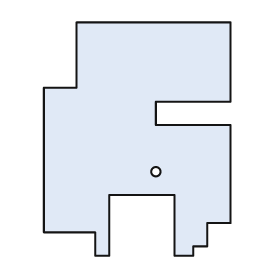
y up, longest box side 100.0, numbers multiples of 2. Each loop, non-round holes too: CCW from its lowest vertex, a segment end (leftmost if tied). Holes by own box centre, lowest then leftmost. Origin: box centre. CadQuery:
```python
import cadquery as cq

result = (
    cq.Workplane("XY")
    .moveTo(-18.0, -50.0)
    .lineTo(-12.0, -50.0)
    .lineTo(-12.0, -24.0)
    .lineTo(16.0, -24.0)
    .lineTo(16.0, -50.0)
    .lineTo(24.0, -50.0)
    .lineTo(24.0, -46.0)
    .lineTo(30.0, -46.0)
    .lineTo(30.0, -36.0)
    .lineTo(40.0, -36.0)
    .lineTo(40.0, 6.0)
    .lineTo(8.0, 6.0)
    .lineTo(8.0, 16.0)
    .lineTo(40.0, 16.0)
    .lineTo(40.0, 50.0)
    .lineTo(-26.0, 50.0)
    .lineTo(-26.0, 22.0)
    .lineTo(-40.0, 22.0)
    .lineTo(-40.0, -40.0)
    .lineTo(-18.0, -40.0)
    .close()
    .moveTo(8.0, -14.0)
    .circle(2.0)
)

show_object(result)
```